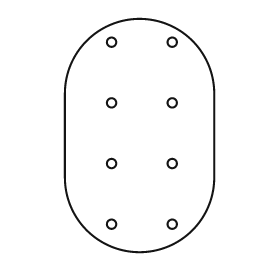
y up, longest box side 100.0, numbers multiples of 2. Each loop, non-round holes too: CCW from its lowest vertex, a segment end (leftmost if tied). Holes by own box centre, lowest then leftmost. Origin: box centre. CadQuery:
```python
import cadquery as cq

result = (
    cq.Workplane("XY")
    .moveTo(-32.0, -18.0)
    .threePointArc((0.0, -50.0), (32.0, -18.0))
    .lineTo(32.0, 18.0)
    .threePointArc((0.0, 50.0), (-32.0, 18.0))
    .close()
    .moveTo(-12.0, -38.0)
    .circle(2.0)
    .moveTo(14.0, -38.0)
    .circle(2.0)
    .moveTo(-12.0, -12.0)
    .circle(2.0)
    .moveTo(14.0, -12.0)
    .circle(2.0)
    .moveTo(-12.0, 14.0)
    .circle(2.0)
    .moveTo(14.0, 14.0)
    .circle(2.0)
    .moveTo(-12.0, 40.0)
    .circle(2.0)
    .moveTo(14.0, 40.0)
    .circle(2.0)
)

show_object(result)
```